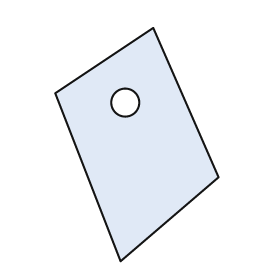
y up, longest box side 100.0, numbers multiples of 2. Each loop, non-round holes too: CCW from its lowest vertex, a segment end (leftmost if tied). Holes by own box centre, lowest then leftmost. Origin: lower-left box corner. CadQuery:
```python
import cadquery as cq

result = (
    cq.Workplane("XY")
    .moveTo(28.0, 0.0)
    .lineTo(70.0, 36.0)
    .lineTo(42.0, 100.0)
    .lineTo(0.0, 72.0)
    .close()
    .moveTo(30.0, 68.0)
    .circle(6.0)
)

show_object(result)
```